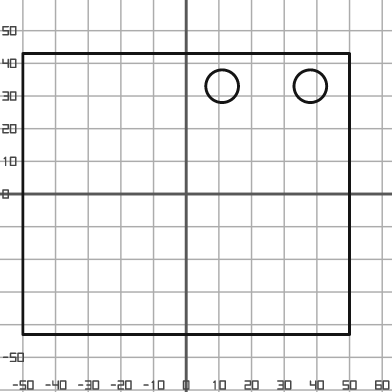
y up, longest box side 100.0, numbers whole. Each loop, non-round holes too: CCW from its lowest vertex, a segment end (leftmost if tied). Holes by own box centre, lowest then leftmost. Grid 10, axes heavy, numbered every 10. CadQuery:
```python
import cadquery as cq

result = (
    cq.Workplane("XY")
    .moveTo(-50.0, -43.0)
    .lineTo(50.0, -43.0)
    .lineTo(50.0, 43.0)
    .lineTo(-50.0, 43.0)
    .close()
    .moveTo(11.0, 33.0)
    .circle(5.0)
    .moveTo(38.0, 33.0)
    .circle(5.0)
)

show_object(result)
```